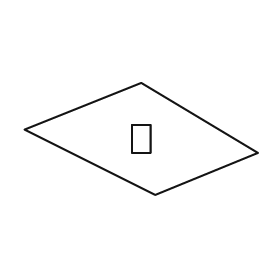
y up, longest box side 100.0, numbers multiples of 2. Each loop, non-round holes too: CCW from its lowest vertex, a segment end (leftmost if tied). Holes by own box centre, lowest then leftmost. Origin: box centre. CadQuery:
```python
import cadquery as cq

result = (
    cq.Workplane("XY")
    .moveTo(6.0, -24.0)
    .lineTo(50.0, -6.0)
    .lineTo(0.0, 24.0)
    .lineTo(-50.0, 4.0)
    .close()
    .moveTo(-4.0, -6.0)
    .lineTo(4.0, -6.0)
    .lineTo(4.0, 6.0)
    .lineTo(-4.0, 6.0)
    .close()
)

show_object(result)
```